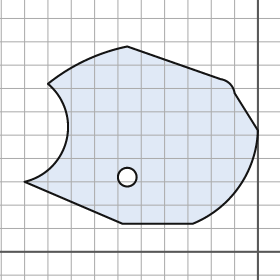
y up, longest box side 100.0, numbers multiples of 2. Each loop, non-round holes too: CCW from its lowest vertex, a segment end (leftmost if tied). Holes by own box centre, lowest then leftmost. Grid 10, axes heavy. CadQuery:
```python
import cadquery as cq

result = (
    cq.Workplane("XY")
    .moveTo(-58.0, 12.0)
    .lineTo(-28.0, 12.0)
    .threePointArc((-8.0, 28.0), (0.0, 52.0))
    .lineTo(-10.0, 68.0)
    .threePointArc((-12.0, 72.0), (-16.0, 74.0))
    .lineTo(-56.0, 88.0)
    .threePointArc((-74.0, 82.0), (-90.0, 72.0))
    .threePointArc((-82.0, 48.0), (-100.0, 30.0))
    .close()
    .moveTo(-56.0, 32.0)
    .circle(4.0)
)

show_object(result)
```